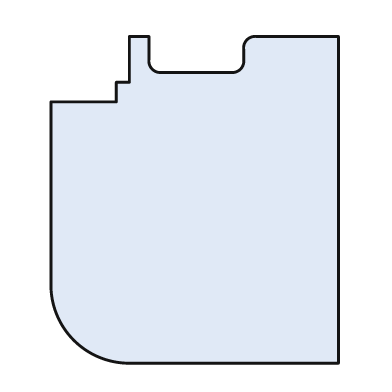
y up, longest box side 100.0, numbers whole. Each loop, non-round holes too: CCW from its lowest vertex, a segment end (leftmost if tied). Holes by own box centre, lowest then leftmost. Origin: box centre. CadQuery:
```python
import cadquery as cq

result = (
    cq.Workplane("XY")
    .moveTo(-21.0, -50.0)
    .lineTo(44.0, -50.0)
    .lineTo(44.0, 50.0)
    .lineTo(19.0, 50.0)
    .threePointArc((16.0, 49.0), (15.0, 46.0))
    .lineTo(15.0, 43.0)
    .threePointArc((14.0, 40.0), (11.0, 39.0))
    .lineTo(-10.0, 39.0)
    .threePointArc((-13.0, 40.0), (-14.0, 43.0))
    .lineTo(-14.0, 50.0)
    .lineTo(-20.0, 50.0)
    .lineTo(-20.0, 36.0)
    .lineTo(-24.0, 36.0)
    .lineTo(-24.0, 30.0)
    .lineTo(-44.0, 30.0)
    .lineTo(-44.0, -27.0)
    .threePointArc((-37.0, -43.0), (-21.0, -50.0))
    .close()
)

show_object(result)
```